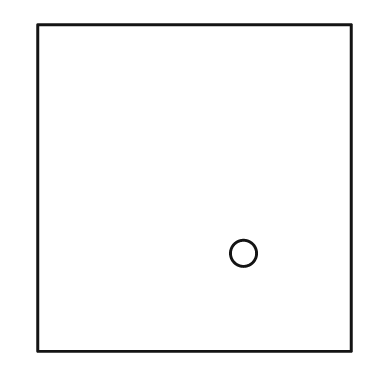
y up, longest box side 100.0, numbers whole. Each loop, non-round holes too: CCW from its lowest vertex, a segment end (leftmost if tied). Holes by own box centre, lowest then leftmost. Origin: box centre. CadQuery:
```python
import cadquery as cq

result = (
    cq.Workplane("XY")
    .moveTo(-48.0, -50.0)
    .lineTo(48.0, -50.0)
    .lineTo(48.0, 50.0)
    .lineTo(-48.0, 50.0)
    .close()
    .moveTo(15.0, -20.0)
    .circle(4.0)
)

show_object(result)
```